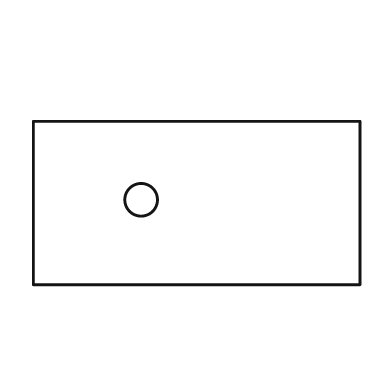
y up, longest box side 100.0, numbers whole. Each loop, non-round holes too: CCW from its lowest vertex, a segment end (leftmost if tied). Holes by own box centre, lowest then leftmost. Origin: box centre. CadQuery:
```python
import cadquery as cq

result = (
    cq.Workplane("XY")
    .moveTo(-50.0, -25.0)
    .lineTo(50.0, -25.0)
    .lineTo(50.0, 25.0)
    .lineTo(-50.0, 25.0)
    .close()
    .moveTo(-17.0, 1.0)
    .circle(5.0)
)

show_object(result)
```